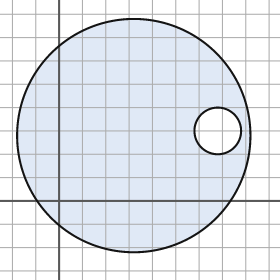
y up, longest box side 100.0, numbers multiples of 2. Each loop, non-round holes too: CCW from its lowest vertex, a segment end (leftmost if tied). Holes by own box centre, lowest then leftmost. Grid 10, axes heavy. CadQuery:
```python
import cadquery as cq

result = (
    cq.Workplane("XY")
    .moveTo(32.0, 28.0)
    .circle(50.0)
    .moveTo(68.0, 30.0)
    .circle(10.0)
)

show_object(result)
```